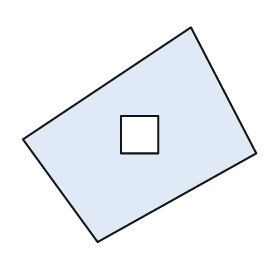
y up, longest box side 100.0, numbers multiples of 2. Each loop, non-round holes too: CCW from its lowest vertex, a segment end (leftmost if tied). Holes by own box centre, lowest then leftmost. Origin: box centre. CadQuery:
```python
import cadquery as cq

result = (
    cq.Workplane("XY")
    .moveTo(-18.0, -46.0)
    .lineTo(50.0, -8.0)
    .lineTo(22.0, 46.0)
    .lineTo(-50.0, -2.0)
    .close()
    .moveTo(-8.0, -8.0)
    .lineTo(8.0, -8.0)
    .lineTo(8.0, 8.0)
    .lineTo(-8.0, 8.0)
    .close()
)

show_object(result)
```